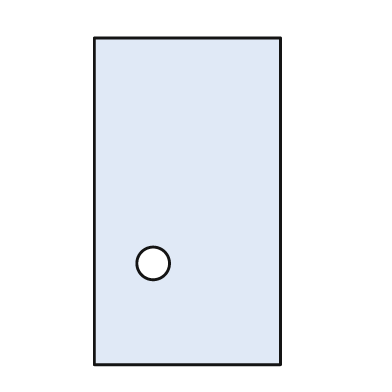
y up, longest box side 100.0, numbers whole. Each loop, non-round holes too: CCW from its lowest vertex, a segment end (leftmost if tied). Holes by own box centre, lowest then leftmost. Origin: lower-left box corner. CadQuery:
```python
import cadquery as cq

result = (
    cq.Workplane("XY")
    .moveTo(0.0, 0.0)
    .lineTo(57.0, 0.0)
    .lineTo(57.0, 100.0)
    .lineTo(0.0, 100.0)
    .close()
    .moveTo(18.0, 31.0)
    .circle(5.0)
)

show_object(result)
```